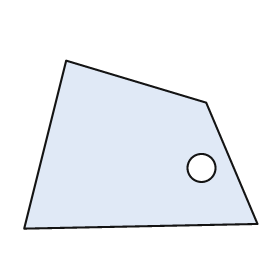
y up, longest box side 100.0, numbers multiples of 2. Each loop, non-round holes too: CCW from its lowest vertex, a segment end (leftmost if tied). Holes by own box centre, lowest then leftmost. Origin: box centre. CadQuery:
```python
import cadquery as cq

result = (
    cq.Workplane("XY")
    .moveTo(-50.0, -36.0)
    .lineTo(50.0, -34.0)
    .lineTo(28.0, 18.0)
    .lineTo(-32.0, 36.0)
    .close()
    .moveTo(26.0, -10.0)
    .circle(6.0)
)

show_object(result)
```